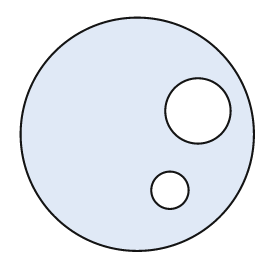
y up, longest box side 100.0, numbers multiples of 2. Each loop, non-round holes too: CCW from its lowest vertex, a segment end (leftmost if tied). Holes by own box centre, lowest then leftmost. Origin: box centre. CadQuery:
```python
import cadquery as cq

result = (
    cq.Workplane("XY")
    .moveTo(0.0, 0.0)
    .circle(50.0)
    .moveTo(14.0, -24.0)
    .circle(8.0)
    .moveTo(26.0, 10.0)
    .circle(14.0)
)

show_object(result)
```